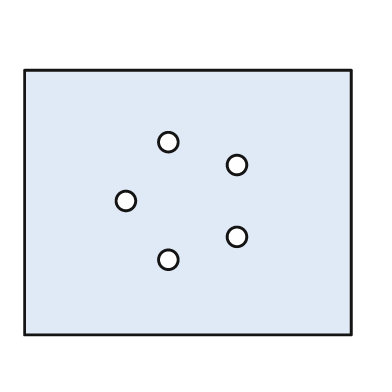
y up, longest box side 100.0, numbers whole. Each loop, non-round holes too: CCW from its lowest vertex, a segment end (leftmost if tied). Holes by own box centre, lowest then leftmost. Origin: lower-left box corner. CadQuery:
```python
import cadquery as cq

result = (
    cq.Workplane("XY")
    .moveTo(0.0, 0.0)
    .lineTo(100.0, 0.0)
    .lineTo(100.0, 81.0)
    .lineTo(0.0, 81.0)
    .close()
    .moveTo(44.0, 23.0)
    .circle(3.0)
    .moveTo(65.0, 30.0)
    .circle(3.0)
    .moveTo(31.0, 41.0)
    .circle(3.0)
    .moveTo(65.0, 52.0)
    .circle(3.0)
    .moveTo(44.0, 59.0)
    .circle(3.0)
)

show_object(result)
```